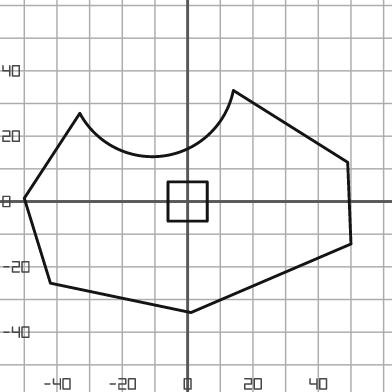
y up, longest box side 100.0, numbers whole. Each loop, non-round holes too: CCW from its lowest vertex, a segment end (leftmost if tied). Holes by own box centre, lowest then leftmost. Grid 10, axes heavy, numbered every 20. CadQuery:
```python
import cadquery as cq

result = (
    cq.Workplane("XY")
    .moveTo(1.0, -34.0)
    .lineTo(50.0, -13.0)
    .lineTo(49.0, 12.0)
    .lineTo(14.0, 34.0)
    .threePointArc((-7.0, 14.0), (-33.0, 27.0))
    .lineTo(-50.0, 1.0)
    .lineTo(-42.0, -25.0)
    .close()
    .moveTo(-6.0, -6.0)
    .lineTo(6.0, -6.0)
    .lineTo(6.0, 6.0)
    .lineTo(-6.0, 6.0)
    .close()
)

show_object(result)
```